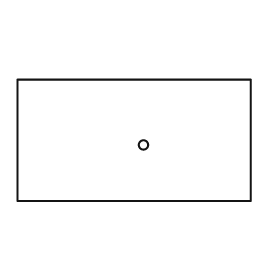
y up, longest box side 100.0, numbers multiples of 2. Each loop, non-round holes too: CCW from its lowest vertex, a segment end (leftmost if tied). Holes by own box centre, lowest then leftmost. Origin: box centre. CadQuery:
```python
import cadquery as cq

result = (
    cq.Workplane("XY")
    .moveTo(-50.0, -26.0)
    .lineTo(50.0, -26.0)
    .lineTo(50.0, 26.0)
    .lineTo(-50.0, 26.0)
    .close()
    .moveTo(4.0, -2.0)
    .circle(2.0)
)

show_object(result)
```